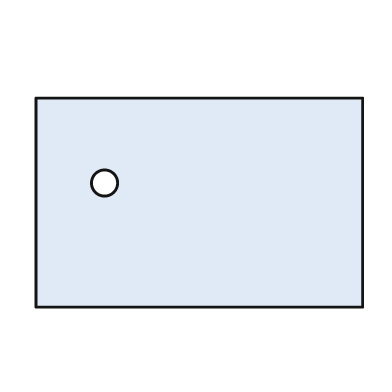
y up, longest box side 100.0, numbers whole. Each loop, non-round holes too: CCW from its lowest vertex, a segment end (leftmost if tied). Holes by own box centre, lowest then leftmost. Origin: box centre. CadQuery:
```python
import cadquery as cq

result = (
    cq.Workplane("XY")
    .moveTo(-50.0, -32.0)
    .lineTo(50.0, -32.0)
    .lineTo(50.0, 32.0)
    .lineTo(-50.0, 32.0)
    .close()
    .moveTo(-29.0, 6.0)
    .circle(4.0)
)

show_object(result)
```